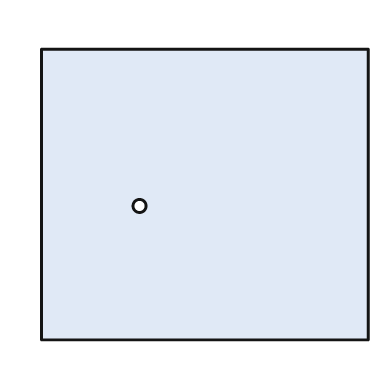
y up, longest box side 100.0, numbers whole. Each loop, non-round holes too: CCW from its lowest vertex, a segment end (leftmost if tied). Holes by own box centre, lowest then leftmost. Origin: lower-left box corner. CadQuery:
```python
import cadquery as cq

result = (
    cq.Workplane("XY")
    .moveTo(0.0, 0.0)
    .lineTo(100.0, 0.0)
    .lineTo(100.0, 89.0)
    .lineTo(0.0, 89.0)
    .close()
    .moveTo(30.0, 41.0)
    .circle(2.0)
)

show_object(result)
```